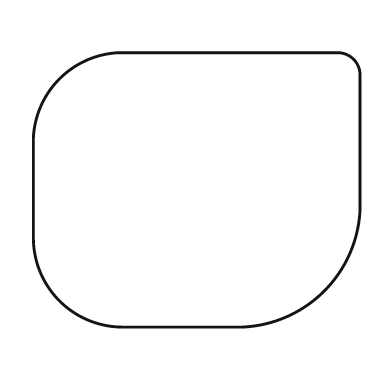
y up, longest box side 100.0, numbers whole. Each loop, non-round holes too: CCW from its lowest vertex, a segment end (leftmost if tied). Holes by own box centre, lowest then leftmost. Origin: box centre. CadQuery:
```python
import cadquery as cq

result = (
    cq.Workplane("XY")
    .moveTo(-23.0, -42.0)
    .lineTo(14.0, -42.0)
    .threePointArc((39.0, -31.0), (50.0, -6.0))
    .lineTo(50.0, 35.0)
    .threePointArc((48.0, 40.0), (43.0, 42.0))
    .lineTo(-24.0, 42.0)
    .threePointArc((-42.0, 34.0), (-50.0, 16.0))
    .lineTo(-50.0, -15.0)
    .threePointArc((-42.0, -34.0), (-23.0, -42.0))
    .close()
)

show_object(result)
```